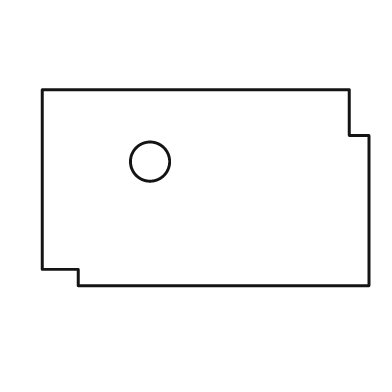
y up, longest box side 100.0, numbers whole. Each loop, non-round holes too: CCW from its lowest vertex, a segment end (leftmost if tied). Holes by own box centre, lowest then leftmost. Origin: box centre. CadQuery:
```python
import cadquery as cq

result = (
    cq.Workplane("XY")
    .moveTo(-39.0, -30.0)
    .lineTo(50.0, -30.0)
    .lineTo(50.0, 16.0)
    .lineTo(44.0, 16.0)
    .lineTo(44.0, 30.0)
    .lineTo(-50.0, 30.0)
    .lineTo(-50.0, -25.0)
    .lineTo(-39.0, -25.0)
    .close()
    .moveTo(-17.0, 8.0)
    .circle(6.0)
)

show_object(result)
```